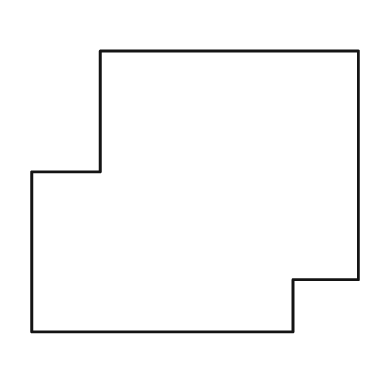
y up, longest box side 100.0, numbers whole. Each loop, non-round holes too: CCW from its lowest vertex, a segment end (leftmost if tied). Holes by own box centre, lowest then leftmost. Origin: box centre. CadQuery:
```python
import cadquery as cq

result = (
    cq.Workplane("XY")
    .moveTo(-50.0, -43.0)
    .lineTo(30.0, -43.0)
    .lineTo(30.0, -27.0)
    .lineTo(50.0, -27.0)
    .lineTo(50.0, 43.0)
    .lineTo(-29.0, 43.0)
    .lineTo(-29.0, 6.0)
    .lineTo(-50.0, 6.0)
    .close()
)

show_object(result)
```